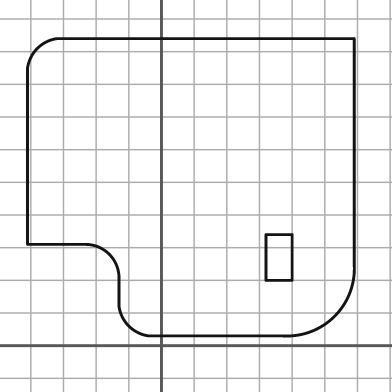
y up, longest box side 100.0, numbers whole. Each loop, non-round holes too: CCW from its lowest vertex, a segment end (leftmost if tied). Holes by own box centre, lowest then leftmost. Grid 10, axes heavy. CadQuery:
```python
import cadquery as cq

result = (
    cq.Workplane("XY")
    .moveTo(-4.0, 3.0)
    .lineTo(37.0, 3.0)
    .threePointArc((53.0, 9.0), (59.0, 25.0))
    .lineTo(59.0, 94.0)
    .lineTo(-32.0, 94.0)
    .threePointArc((-38.0, 91.0), (-41.0, 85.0))
    .lineTo(-41.0, 31.0)
    .lineTo(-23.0, 31.0)
    .threePointArc((-16.0, 28.0), (-13.0, 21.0))
    .lineTo(-13.0, 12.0)
    .threePointArc((-10.0, 6.0), (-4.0, 3.0))
    .close()
    .moveTo(32.0, 20.0)
    .lineTo(40.0, 20.0)
    .lineTo(40.0, 34.0)
    .lineTo(32.0, 34.0)
    .close()
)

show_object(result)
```